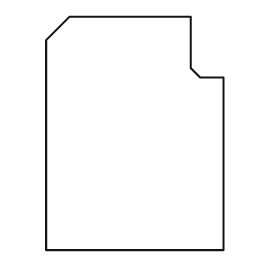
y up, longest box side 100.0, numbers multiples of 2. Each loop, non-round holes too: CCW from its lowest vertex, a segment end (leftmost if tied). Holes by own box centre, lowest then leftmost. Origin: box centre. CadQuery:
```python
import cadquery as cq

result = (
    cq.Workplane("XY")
    .moveTo(-38.0, -50.0)
    .lineTo(38.0, -50.0)
    .lineTo(38.0, 24.0)
    .lineTo(28.0, 24.0)
    .lineTo(24.0, 28.0)
    .lineTo(24.0, 50.0)
    .lineTo(-28.0, 50.0)
    .lineTo(-38.0, 40.0)
    .close()
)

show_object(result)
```